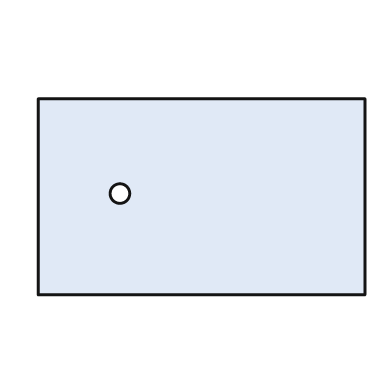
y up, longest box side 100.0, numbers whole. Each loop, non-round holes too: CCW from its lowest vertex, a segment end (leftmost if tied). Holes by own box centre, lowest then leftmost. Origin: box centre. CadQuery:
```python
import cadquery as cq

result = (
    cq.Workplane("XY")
    .moveTo(-50.0, -30.0)
    .lineTo(50.0, -30.0)
    .lineTo(50.0, 30.0)
    .lineTo(-50.0, 30.0)
    .close()
    .moveTo(-25.0, 1.0)
    .circle(3.0)
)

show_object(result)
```